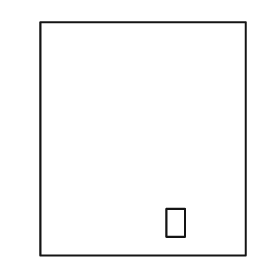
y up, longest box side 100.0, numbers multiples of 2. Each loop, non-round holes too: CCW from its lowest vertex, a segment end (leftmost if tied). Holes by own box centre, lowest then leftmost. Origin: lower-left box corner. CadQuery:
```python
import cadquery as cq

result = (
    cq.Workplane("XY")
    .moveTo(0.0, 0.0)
    .lineTo(88.0, 0.0)
    .lineTo(88.0, 100.0)
    .lineTo(0.0, 100.0)
    .close()
    .moveTo(54.0, 8.0)
    .lineTo(62.0, 8.0)
    .lineTo(62.0, 20.0)
    .lineTo(54.0, 20.0)
    .close()
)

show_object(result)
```